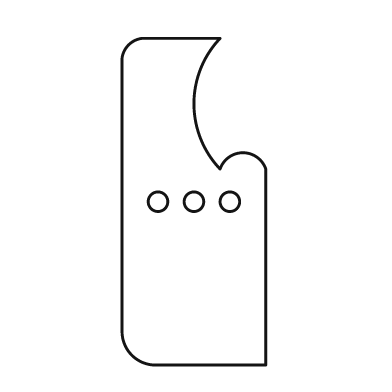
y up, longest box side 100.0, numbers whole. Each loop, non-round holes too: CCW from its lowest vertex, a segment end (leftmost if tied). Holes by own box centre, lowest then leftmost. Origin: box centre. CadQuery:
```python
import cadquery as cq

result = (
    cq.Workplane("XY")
    .moveTo(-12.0, -50.0)
    .lineTo(22.0, -50.0)
    .lineTo(22.0, 10.0)
    .threePointArc((15.0, 15.0), (8.0, 10.0))
    .threePointArc((0.0, 30.0), (8.0, 50.0))
    .lineTo(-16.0, 50.0)
    .threePointArc((-20.0, 48.0), (-22.0, 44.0))
    .lineTo(-22.0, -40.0)
    .threePointArc((-19.0, -47.0), (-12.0, -50.0))
    .close()
    .moveTo(-11.0, 0.0)
    .circle(3.0)
    .moveTo(0.0, 0.0)
    .circle(3.0)
    .moveTo(11.0, 0.0)
    .circle(3.0)
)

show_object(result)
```